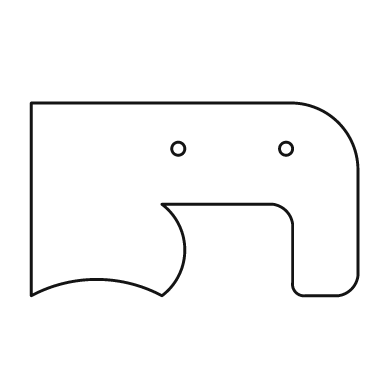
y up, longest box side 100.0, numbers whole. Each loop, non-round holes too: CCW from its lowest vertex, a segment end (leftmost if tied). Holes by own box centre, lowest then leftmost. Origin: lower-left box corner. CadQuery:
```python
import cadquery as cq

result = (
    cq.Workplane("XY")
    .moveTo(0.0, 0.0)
    .threePointArc((20.0, 5.0), (40.0, 0.0))
    .threePointArc((47.0, 14.0), (40.0, 28.0))
    .lineTo(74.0, 28.0)
    .threePointArc((78.0, 26.0), (80.0, 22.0))
    .lineTo(80.0, 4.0)
    .threePointArc((81.0, 1.0), (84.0, 0.0))
    .lineTo(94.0, 0.0)
    .threePointArc((98.0, 2.0), (100.0, 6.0))
    .lineTo(100.0, 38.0)
    .threePointArc((94.0, 53.0), (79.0, 59.0))
    .lineTo(0.0, 59.0)
    .close()
    .moveTo(45.0, 45.0)
    .circle(2.0)
    .moveTo(78.0, 45.0)
    .circle(2.0)
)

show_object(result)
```